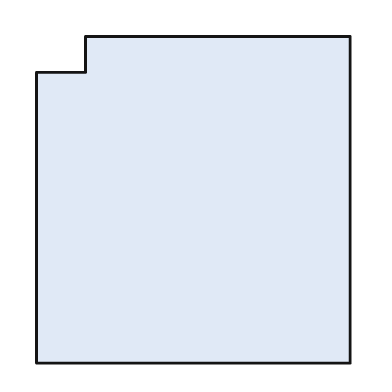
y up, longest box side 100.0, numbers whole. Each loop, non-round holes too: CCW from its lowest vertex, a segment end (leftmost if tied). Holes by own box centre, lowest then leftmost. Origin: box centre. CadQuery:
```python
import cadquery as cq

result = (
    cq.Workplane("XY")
    .moveTo(-48.0, -50.0)
    .lineTo(48.0, -50.0)
    .lineTo(48.0, 50.0)
    .lineTo(-33.0, 50.0)
    .lineTo(-33.0, 39.0)
    .lineTo(-48.0, 39.0)
    .close()
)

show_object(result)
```